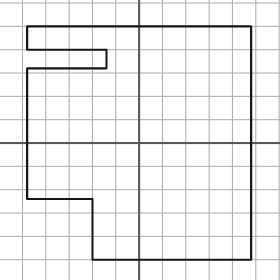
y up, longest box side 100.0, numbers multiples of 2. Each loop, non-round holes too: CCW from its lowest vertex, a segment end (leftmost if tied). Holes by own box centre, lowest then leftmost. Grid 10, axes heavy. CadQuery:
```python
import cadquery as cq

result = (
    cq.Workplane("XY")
    .moveTo(-20.0, -50.0)
    .lineTo(48.0, -50.0)
    .lineTo(48.0, 50.0)
    .lineTo(-48.0, 50.0)
    .lineTo(-48.0, 40.0)
    .lineTo(-14.0, 40.0)
    .lineTo(-14.0, 32.0)
    .lineTo(-48.0, 32.0)
    .lineTo(-48.0, -24.0)
    .lineTo(-20.0, -24.0)
    .close()
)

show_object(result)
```